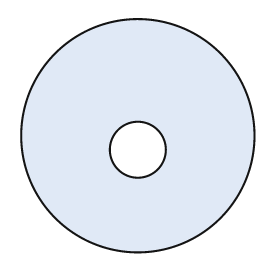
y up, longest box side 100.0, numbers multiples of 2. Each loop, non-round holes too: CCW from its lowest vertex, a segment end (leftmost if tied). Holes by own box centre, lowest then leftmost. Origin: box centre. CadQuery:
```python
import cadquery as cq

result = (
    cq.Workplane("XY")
    .moveTo(0.0, 0.0)
    .circle(50.0)
    .moveTo(0.0, -6.0)
    .circle(12.0)
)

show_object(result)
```